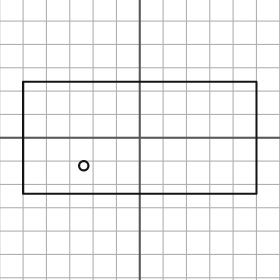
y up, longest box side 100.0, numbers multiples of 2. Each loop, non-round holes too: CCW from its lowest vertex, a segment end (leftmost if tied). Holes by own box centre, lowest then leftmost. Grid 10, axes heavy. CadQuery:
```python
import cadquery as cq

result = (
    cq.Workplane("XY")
    .moveTo(-50.0, -24.0)
    .lineTo(50.0, -24.0)
    .lineTo(50.0, 24.0)
    .lineTo(-50.0, 24.0)
    .close()
    .moveTo(-24.0, -12.0)
    .circle(2.0)
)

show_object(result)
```